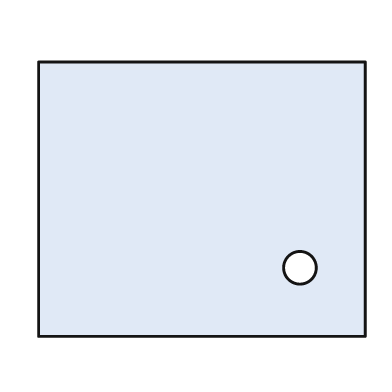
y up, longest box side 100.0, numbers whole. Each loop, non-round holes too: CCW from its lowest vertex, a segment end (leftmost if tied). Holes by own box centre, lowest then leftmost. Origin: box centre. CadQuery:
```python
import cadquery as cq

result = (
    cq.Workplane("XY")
    .moveTo(-50.0, -42.0)
    .lineTo(50.0, -42.0)
    .lineTo(50.0, 42.0)
    .lineTo(-50.0, 42.0)
    .close()
    .moveTo(30.0, -21.0)
    .circle(5.0)
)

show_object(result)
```